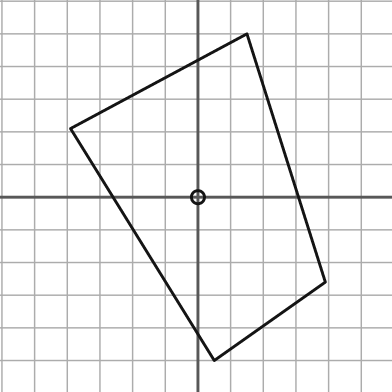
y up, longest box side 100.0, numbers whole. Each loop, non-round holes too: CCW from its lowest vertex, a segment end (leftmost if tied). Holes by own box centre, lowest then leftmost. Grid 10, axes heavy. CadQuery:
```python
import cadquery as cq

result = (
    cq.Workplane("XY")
    .moveTo(5.0, -50.0)
    .lineTo(39.0, -26.0)
    .lineTo(15.0, 50.0)
    .lineTo(-39.0, 21.0)
    .close()
    .moveTo(0.0, 0.0)
    .circle(2.0)
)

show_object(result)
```